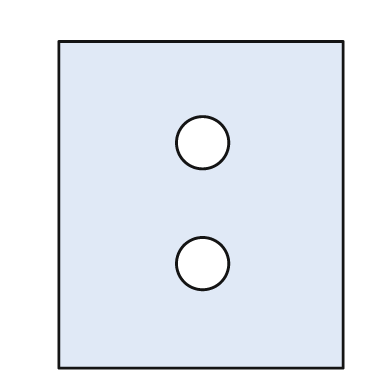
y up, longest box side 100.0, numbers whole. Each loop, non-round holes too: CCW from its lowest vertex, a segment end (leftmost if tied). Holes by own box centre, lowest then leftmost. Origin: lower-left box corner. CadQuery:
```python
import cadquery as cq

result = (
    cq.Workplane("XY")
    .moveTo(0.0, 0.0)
    .lineTo(87.0, 0.0)
    .lineTo(87.0, 100.0)
    .lineTo(0.0, 100.0)
    .close()
    .moveTo(44.0, 32.0)
    .circle(8.0)
    .moveTo(44.0, 69.0)
    .circle(8.0)
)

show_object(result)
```